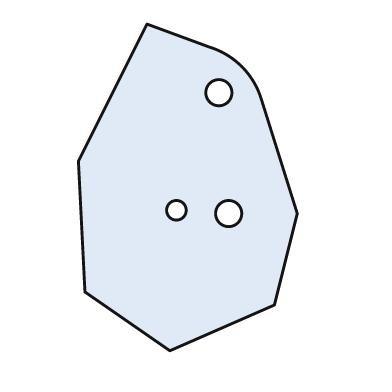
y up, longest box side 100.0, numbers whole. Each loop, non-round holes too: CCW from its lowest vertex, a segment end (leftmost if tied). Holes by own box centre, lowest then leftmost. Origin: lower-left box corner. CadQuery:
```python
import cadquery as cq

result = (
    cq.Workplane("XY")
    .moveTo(28.0, 0.0)
    .lineTo(60.0, 14.0)
    .lineTo(67.0, 42.0)
    .lineTo(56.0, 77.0)
    .threePointArc((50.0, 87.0), (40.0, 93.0))
    .lineTo(21.0, 100.0)
    .lineTo(0.0, 58.0)
    .lineTo(2.0, 18.0)
    .close()
    .moveTo(46.0, 42.0)
    .circle(4.0)
    .moveTo(30.0, 43.0)
    .circle(3.0)
    .moveTo(43.0, 79.0)
    .circle(4.0)
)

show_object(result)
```